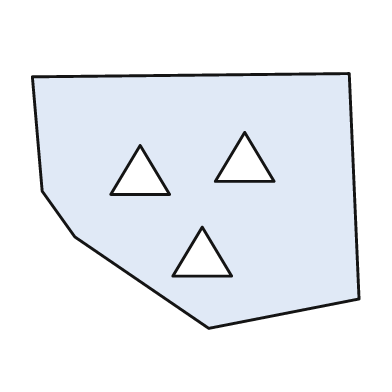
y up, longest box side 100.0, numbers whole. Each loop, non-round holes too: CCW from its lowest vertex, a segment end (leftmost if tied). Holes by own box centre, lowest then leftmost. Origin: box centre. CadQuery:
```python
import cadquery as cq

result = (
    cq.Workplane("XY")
    .moveTo(4.0, -39.0)
    .lineTo(50.0, -30.0)
    .lineTo(47.0, 39.0)
    .lineTo(-50.0, 38.0)
    .lineTo(-47.0, 3.0)
    .lineTo(-37.0, -11.0)
    .close()
    .moveTo(-7.0, -23.0)
    .lineTo(11.0, -23.0)
    .lineTo(2.0, -8.0)
    .close()
    .moveTo(-26.0, 2.0)
    .lineTo(-8.0, 2.0)
    .lineTo(-17.0, 17.0)
    .close()
    .moveTo(6.0, 6.0)
    .lineTo(24.0, 6.0)
    .lineTo(15.0, 21.0)
    .close()
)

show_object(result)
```